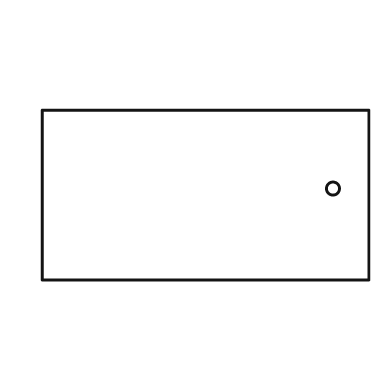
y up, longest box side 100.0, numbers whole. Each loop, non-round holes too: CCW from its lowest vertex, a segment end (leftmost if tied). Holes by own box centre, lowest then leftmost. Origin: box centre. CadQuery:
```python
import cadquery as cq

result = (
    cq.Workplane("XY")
    .moveTo(-50.0, -26.0)
    .lineTo(50.0, -26.0)
    .lineTo(50.0, 26.0)
    .lineTo(-50.0, 26.0)
    .close()
    .moveTo(39.0, 2.0)
    .circle(2.0)
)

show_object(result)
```